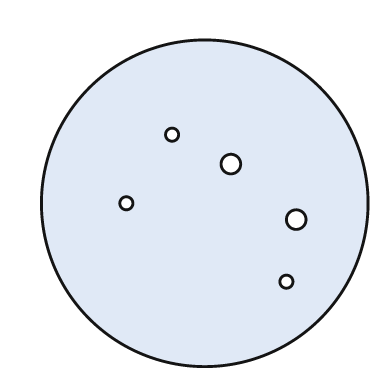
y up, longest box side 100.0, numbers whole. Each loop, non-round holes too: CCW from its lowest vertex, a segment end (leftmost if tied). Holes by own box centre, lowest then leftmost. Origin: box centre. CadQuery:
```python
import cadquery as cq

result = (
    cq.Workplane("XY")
    .moveTo(0.0, 0.0)
    .circle(50.0)
    .moveTo(25.0, -24.0)
    .circle(2.0)
    .moveTo(28.0, -5.0)
    .circle(3.0)
    .moveTo(-24.0, 0.0)
    .circle(2.0)
    .moveTo(8.0, 12.0)
    .circle(3.0)
    .moveTo(-10.0, 21.0)
    .circle(2.0)
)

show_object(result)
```